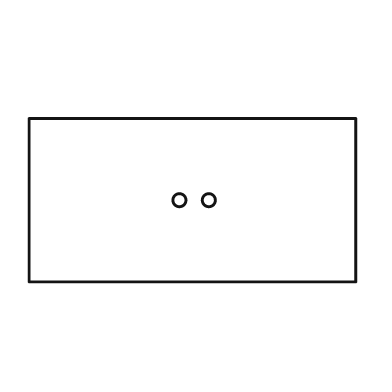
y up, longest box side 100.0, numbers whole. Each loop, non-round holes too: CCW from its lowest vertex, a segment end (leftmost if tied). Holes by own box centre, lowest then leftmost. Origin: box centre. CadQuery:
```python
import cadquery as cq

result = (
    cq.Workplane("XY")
    .moveTo(-50.0, -25.0)
    .lineTo(50.0, -25.0)
    .lineTo(50.0, 25.0)
    .lineTo(-50.0, 25.0)
    .close()
    .moveTo(-4.0, 0.0)
    .circle(2.0)
    .moveTo(5.0, 0.0)
    .circle(2.0)
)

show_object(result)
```